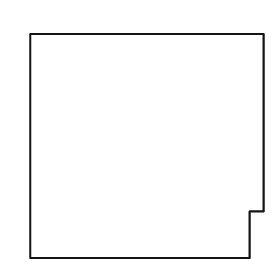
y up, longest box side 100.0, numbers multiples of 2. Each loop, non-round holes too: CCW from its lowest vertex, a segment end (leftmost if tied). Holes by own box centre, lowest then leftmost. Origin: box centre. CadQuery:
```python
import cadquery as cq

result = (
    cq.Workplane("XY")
    .moveTo(-50.0, -48.0)
    .lineTo(44.0, -48.0)
    .lineTo(44.0, -28.0)
    .lineTo(50.0, -28.0)
    .lineTo(50.0, 48.0)
    .lineTo(-50.0, 48.0)
    .close()
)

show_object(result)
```